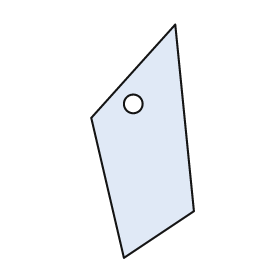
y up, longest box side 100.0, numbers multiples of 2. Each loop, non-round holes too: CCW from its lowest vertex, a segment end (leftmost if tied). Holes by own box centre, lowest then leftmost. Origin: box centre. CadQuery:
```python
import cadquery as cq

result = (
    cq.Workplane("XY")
    .moveTo(-8.0, -50.0)
    .lineTo(22.0, -30.0)
    .lineTo(14.0, 50.0)
    .lineTo(-22.0, 10.0)
    .close()
    .moveTo(-4.0, 16.0)
    .circle(4.0)
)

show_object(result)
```